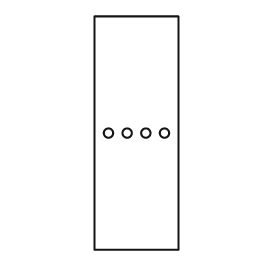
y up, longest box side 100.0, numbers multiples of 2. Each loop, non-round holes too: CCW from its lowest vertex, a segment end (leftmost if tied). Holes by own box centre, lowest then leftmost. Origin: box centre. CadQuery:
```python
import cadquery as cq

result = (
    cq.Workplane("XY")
    .moveTo(-18.0, -50.0)
    .lineTo(18.0, -50.0)
    .lineTo(18.0, 50.0)
    .lineTo(-18.0, 50.0)
    .close()
    .moveTo(-12.0, 0.0)
    .circle(2.0)
    .moveTo(-4.0, 0.0)
    .circle(2.0)
    .moveTo(4.0, 0.0)
    .circle(2.0)
    .moveTo(12.0, 0.0)
    .circle(2.0)
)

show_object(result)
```